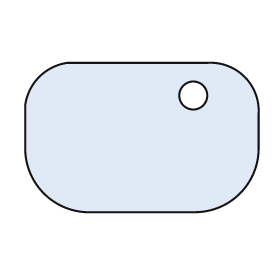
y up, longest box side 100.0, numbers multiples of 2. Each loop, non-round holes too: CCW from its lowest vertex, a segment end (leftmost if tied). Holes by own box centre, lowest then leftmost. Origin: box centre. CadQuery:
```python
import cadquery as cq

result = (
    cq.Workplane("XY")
    .moveTo(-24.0, -32.0)
    .lineTo(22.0, -32.0)
    .threePointArc((42.0, -24.0), (50.0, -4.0))
    .lineTo(50.0, 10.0)
    .threePointArc((44.0, 26.0), (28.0, 32.0))
    .lineTo(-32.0, 32.0)
    .threePointArc((-44.0, 26.0), (-50.0, 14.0))
    .lineTo(-50.0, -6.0)
    .threePointArc((-42.0, -24.0), (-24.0, -32.0))
    .close()
    .moveTo(22.0, 18.0)
    .circle(6.0)
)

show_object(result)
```